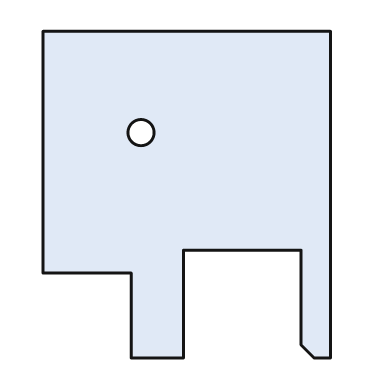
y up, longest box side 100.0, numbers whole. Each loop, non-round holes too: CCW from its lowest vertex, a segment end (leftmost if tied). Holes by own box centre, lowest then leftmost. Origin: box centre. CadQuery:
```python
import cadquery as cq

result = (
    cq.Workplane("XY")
    .moveTo(-17.0, -50.0)
    .lineTo(-1.0, -50.0)
    .lineTo(-1.0, -17.0)
    .lineTo(35.0, -17.0)
    .lineTo(35.0, -46.0)
    .lineTo(39.0, -50.0)
    .lineTo(44.0, -50.0)
    .lineTo(44.0, 50.0)
    .lineTo(-44.0, 50.0)
    .lineTo(-44.0, -24.0)
    .lineTo(-17.0, -24.0)
    .close()
    .moveTo(-14.0, 19.0)
    .circle(4.0)
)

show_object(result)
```